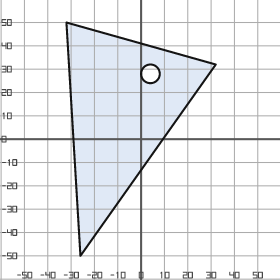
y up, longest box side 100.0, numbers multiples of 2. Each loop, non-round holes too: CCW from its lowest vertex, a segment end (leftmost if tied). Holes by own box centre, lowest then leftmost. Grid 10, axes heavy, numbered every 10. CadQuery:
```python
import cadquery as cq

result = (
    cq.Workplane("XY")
    .moveTo(-26.0, -50.0)
    .lineTo(32.0, 32.0)
    .lineTo(-32.0, 50.0)
    .close()
    .moveTo(4.0, 28.0)
    .circle(4.0)
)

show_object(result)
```